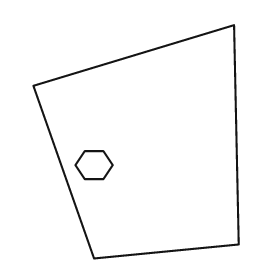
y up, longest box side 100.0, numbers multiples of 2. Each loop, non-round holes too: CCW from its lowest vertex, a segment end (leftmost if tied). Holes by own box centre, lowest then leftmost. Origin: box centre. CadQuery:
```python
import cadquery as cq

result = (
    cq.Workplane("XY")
    .moveTo(-18.0, -50.0)
    .lineTo(44.0, -44.0)
    .lineTo(42.0, 50.0)
    .lineTo(-44.0, 24.0)
    .close()
    .moveTo(-22.0, -16.0)
    .lineTo(-14.0, -16.0)
    .lineTo(-10.0, -10.0)
    .lineTo(-14.0, -4.0)
    .lineTo(-22.0, -4.0)
    .lineTo(-26.0, -10.0)
    .close()
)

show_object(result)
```